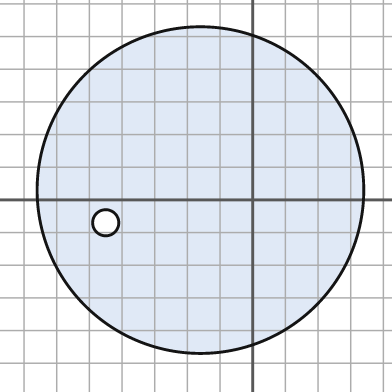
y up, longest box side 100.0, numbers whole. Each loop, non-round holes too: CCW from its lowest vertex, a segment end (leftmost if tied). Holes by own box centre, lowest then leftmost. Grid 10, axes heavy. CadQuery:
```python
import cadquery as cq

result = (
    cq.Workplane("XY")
    .moveTo(-16.0, 3.0)
    .circle(50.0)
    .moveTo(-45.0, -7.0)
    .circle(4.0)
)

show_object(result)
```